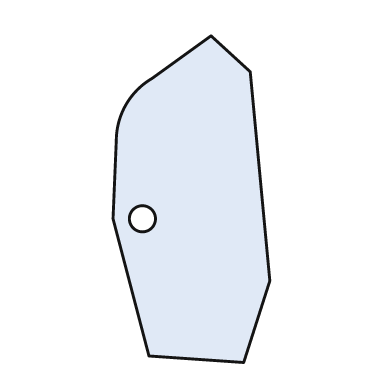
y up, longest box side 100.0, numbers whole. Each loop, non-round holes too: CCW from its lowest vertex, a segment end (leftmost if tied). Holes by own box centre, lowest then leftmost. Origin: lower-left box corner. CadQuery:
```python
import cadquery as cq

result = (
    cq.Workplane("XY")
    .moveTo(40.0, 0.0)
    .lineTo(48.0, 25.0)
    .lineTo(42.0, 89.0)
    .lineTo(30.0, 100.0)
    .lineTo(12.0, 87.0)
    .threePointArc((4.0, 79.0), (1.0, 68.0))
    .lineTo(0.0, 44.0)
    .lineTo(11.0, 2.0)
    .close()
    .moveTo(9.0, 44.0)
    .circle(4.0)
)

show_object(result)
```